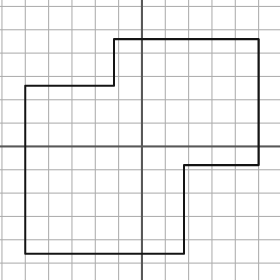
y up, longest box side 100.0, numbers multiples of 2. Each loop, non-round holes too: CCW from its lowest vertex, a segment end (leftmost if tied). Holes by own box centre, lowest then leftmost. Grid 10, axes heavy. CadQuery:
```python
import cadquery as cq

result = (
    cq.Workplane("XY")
    .moveTo(-50.0, -46.0)
    .lineTo(18.0, -46.0)
    .lineTo(18.0, -8.0)
    .lineTo(50.0, -8.0)
    .lineTo(50.0, 46.0)
    .lineTo(-12.0, 46.0)
    .lineTo(-12.0, 26.0)
    .lineTo(-50.0, 26.0)
    .close()
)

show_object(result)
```